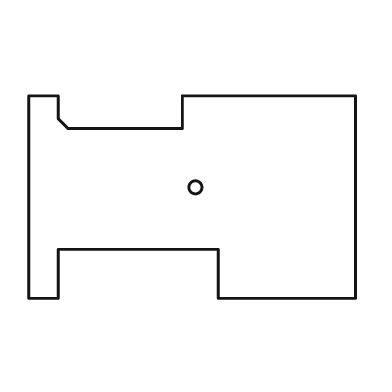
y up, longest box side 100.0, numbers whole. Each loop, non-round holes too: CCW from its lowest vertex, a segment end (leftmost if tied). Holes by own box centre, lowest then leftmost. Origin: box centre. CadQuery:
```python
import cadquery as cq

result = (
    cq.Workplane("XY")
    .moveTo(-50.0, -31.0)
    .lineTo(-41.0, -31.0)
    .lineTo(-41.0, -16.0)
    .lineTo(8.0, -16.0)
    .lineTo(8.0, -31.0)
    .lineTo(50.0, -31.0)
    .lineTo(50.0, 31.0)
    .lineTo(-3.0, 31.0)
    .lineTo(-3.0, 21.0)
    .lineTo(-38.0, 21.0)
    .lineTo(-41.0, 24.0)
    .lineTo(-41.0, 31.0)
    .lineTo(-50.0, 31.0)
    .close()
    .moveTo(1.0, 3.0)
    .circle(2.0)
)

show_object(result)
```